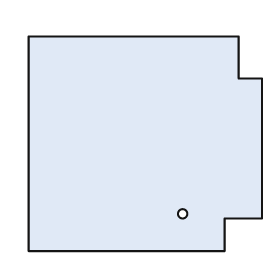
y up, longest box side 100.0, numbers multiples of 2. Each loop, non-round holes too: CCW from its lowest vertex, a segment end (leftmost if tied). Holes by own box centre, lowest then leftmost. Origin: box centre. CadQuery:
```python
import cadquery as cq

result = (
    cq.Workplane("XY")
    .moveTo(-50.0, -46.0)
    .lineTo(34.0, -46.0)
    .lineTo(34.0, -32.0)
    .lineTo(50.0, -32.0)
    .lineTo(50.0, 28.0)
    .lineTo(40.0, 28.0)
    .lineTo(40.0, 46.0)
    .lineTo(-50.0, 46.0)
    .close()
    .moveTo(16.0, -30.0)
    .circle(2.0)
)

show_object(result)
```